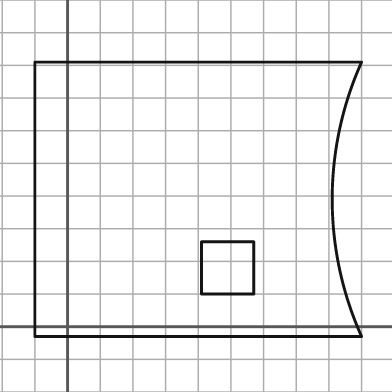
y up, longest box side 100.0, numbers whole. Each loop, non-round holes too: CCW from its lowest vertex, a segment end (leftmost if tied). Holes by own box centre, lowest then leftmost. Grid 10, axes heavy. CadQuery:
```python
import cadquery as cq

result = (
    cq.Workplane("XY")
    .moveTo(-10.0, -3.0)
    .lineTo(90.0, -3.0)
    .threePointArc((81.0, 39.0), (90.0, 81.0))
    .lineTo(-10.0, 81.0)
    .close()
    .moveTo(41.0, 10.0)
    .lineTo(57.0, 10.0)
    .lineTo(57.0, 26.0)
    .lineTo(41.0, 26.0)
    .close()
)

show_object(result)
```